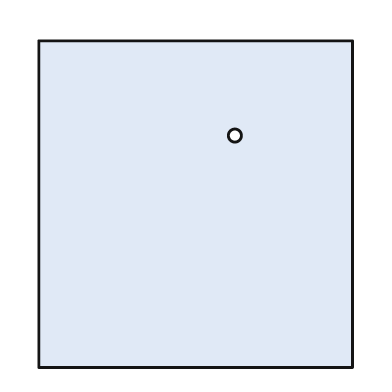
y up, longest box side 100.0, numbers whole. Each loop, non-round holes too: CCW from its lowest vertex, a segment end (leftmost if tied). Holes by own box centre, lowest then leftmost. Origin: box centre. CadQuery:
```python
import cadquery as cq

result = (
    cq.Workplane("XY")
    .moveTo(-48.0, -50.0)
    .lineTo(48.0, -50.0)
    .lineTo(48.0, 50.0)
    .lineTo(-48.0, 50.0)
    .close()
    .moveTo(12.0, 21.0)
    .circle(2.0)
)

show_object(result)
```